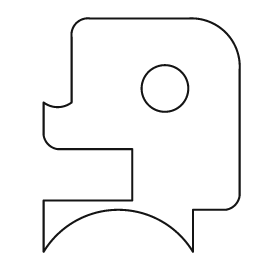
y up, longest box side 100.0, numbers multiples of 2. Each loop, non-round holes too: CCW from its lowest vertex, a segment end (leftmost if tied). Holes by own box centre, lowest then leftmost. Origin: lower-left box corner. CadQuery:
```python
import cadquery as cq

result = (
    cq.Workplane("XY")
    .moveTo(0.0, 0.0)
    .threePointArc((32.0, 18.0), (64.0, 0.0))
    .lineTo(64.0, 18.0)
    .lineTo(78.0, 18.0)
    .threePointArc((82.0, 20.0), (84.0, 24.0))
    .lineTo(84.0, 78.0)
    .threePointArc((78.0, 94.0), (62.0, 100.0))
    .lineTo(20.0, 100.0)
    .threePointArc((14.0, 98.0), (12.0, 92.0))
    .lineTo(12.0, 64.0)
    .threePointArc((6.0, 62.0), (0.0, 64.0))
    .lineTo(0.0, 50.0)
    .threePointArc((2.0, 46.0), (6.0, 44.0))
    .lineTo(38.0, 44.0)
    .lineTo(38.0, 22.0)
    .lineTo(0.0, 22.0)
    .close()
    .moveTo(52.0, 70.0)
    .circle(10.0)
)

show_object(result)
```